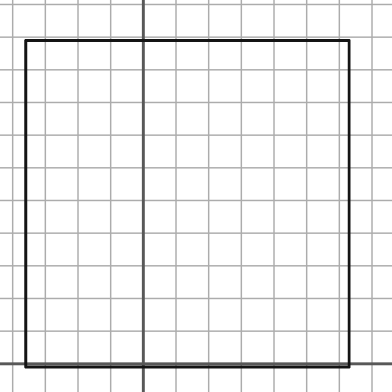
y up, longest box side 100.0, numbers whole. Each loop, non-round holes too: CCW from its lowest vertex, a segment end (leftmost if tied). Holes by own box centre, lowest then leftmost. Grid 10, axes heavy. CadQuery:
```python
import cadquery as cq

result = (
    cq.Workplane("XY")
    .moveTo(-36.0, -1.0)
    .lineTo(63.0, -1.0)
    .lineTo(63.0, 99.0)
    .lineTo(-36.0, 99.0)
    .close()
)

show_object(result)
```